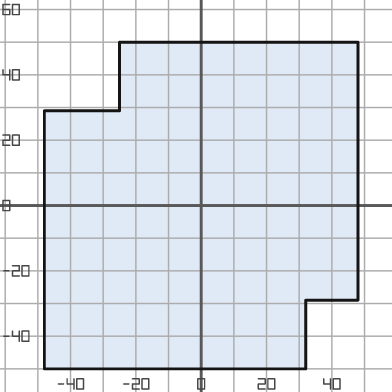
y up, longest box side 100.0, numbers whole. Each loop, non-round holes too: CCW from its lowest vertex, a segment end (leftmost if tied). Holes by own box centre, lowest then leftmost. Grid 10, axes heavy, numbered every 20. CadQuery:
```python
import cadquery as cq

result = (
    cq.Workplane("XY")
    .moveTo(-48.0, -50.0)
    .lineTo(32.0, -50.0)
    .lineTo(32.0, -29.0)
    .lineTo(48.0, -29.0)
    .lineTo(48.0, 50.0)
    .lineTo(-25.0, 50.0)
    .lineTo(-25.0, 29.0)
    .lineTo(-48.0, 29.0)
    .close()
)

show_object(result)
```